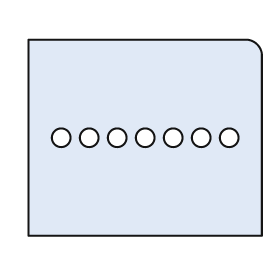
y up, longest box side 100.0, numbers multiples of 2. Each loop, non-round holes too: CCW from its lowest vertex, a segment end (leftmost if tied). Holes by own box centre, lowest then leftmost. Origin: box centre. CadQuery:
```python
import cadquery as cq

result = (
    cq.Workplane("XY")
    .moveTo(-50.0, -42.0)
    .lineTo(50.0, -42.0)
    .lineTo(50.0, 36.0)
    .threePointArc((48.0, 40.0), (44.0, 42.0))
    .lineTo(-50.0, 42.0)
    .close()
    .moveTo(-36.0, 0.0)
    .circle(4.0)
    .moveTo(-24.0, 0.0)
    .circle(4.0)
    .moveTo(-12.0, 0.0)
    .circle(4.0)
    .moveTo(0.0, 0.0)
    .circle(4.0)
    .moveTo(12.0, 0.0)
    .circle(4.0)
    .moveTo(24.0, 0.0)
    .circle(4.0)
    .moveTo(36.0, 0.0)
    .circle(4.0)
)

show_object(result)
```